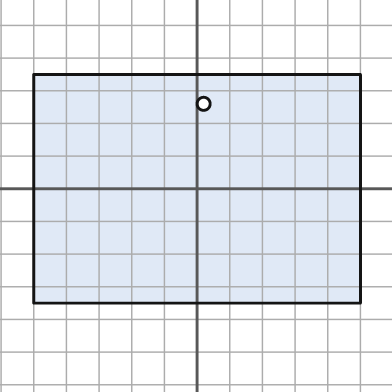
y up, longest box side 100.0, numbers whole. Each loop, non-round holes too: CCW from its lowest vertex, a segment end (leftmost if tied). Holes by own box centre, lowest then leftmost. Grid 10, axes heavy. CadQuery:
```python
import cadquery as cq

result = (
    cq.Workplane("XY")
    .moveTo(-50.0, -35.0)
    .lineTo(50.0, -35.0)
    .lineTo(50.0, 35.0)
    .lineTo(-50.0, 35.0)
    .close()
    .moveTo(2.0, 26.0)
    .circle(2.0)
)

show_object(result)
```